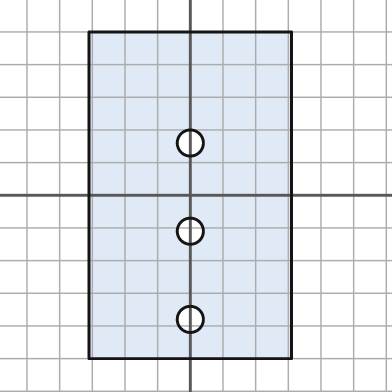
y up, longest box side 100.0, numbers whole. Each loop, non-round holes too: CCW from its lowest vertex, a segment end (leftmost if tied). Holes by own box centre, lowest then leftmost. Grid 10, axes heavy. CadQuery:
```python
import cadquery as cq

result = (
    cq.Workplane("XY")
    .moveTo(-31.0, -50.0)
    .lineTo(31.0, -50.0)
    .lineTo(31.0, 50.0)
    .lineTo(-31.0, 50.0)
    .close()
    .moveTo(0.0, -38.0)
    .circle(4.0)
    .moveTo(0.0, -11.0)
    .circle(4.0)
    .moveTo(0.0, 16.0)
    .circle(4.0)
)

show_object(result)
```